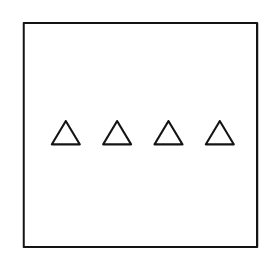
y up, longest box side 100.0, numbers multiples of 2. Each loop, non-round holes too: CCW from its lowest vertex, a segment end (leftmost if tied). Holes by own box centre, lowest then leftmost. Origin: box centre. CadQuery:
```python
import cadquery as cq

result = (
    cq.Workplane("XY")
    .moveTo(-50.0, -48.0)
    .lineTo(50.0, -48.0)
    .lineTo(50.0, 48.0)
    .lineTo(-50.0, 48.0)
    .close()
    .moveTo(-38.0, -4.0)
    .lineTo(-26.0, -4.0)
    .lineTo(-32.0, 6.0)
    .close()
    .moveTo(-16.0, -4.0)
    .lineTo(-4.0, -4.0)
    .lineTo(-10.0, 6.0)
    .close()
    .moveTo(6.0, -4.0)
    .lineTo(18.0, -4.0)
    .lineTo(12.0, 6.0)
    .close()
    .moveTo(28.0, -4.0)
    .lineTo(40.0, -4.0)
    .lineTo(34.0, 6.0)
    .close()
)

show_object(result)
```